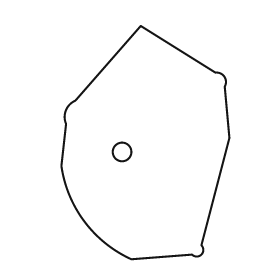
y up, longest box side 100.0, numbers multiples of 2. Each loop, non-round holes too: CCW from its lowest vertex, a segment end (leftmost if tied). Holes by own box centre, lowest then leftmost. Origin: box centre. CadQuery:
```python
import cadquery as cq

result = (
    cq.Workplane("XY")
    .moveTo(-6.0, -50.0)
    .lineTo(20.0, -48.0)
    .threePointArc((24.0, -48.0), (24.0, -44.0))
    .lineTo(36.0, 2.0)
    .lineTo(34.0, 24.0)
    .threePointArc((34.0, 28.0), (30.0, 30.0))
    .lineTo(-2.0, 50.0)
    .lineTo(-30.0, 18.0)
    .threePointArc((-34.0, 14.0), (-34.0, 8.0))
    .lineTo(-36.0, -10.0)
    .threePointArc((-26.0, -34.0), (-6.0, -50.0))
    .close()
    .moveTo(-10.0, -4.0)
    .circle(4.0)
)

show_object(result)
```